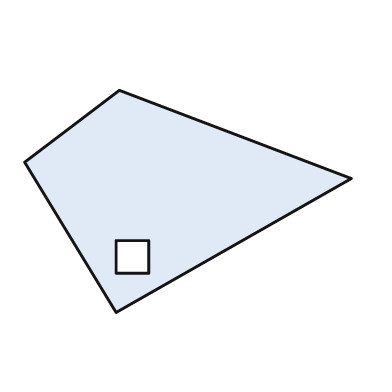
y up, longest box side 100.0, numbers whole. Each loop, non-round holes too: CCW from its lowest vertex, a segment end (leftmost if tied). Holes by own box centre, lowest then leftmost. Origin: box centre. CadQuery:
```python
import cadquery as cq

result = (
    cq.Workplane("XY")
    .moveTo(-22.0, -34.0)
    .lineTo(50.0, 7.0)
    .lineTo(-21.0, 34.0)
    .lineTo(-50.0, 12.0)
    .close()
    .moveTo(-22.0, -22.0)
    .lineTo(-12.0, -22.0)
    .lineTo(-12.0, -12.0)
    .lineTo(-22.0, -12.0)
    .close()
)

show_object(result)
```